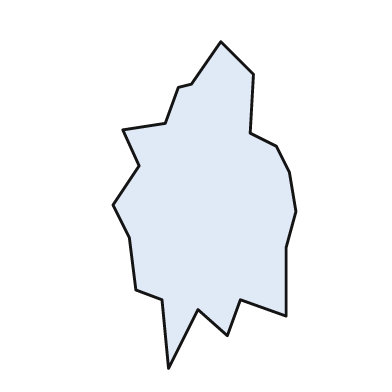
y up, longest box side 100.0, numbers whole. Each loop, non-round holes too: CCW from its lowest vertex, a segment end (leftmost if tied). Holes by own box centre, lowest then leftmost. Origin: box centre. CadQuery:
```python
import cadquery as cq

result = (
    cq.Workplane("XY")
    .moveTo(-11.0, -50.0)
    .lineTo(-2.0, -32.0)
    .lineTo(7.0, -40.0)
    .lineTo(11.0, -29.0)
    .lineTo(25.0, -34.0)
    .lineTo(25.0, -13.0)
    .lineTo(28.0, -2.0)
    .lineTo(26.0, 10.0)
    .lineTo(22.0, 18.0)
    .lineTo(14.0, 22.0)
    .lineTo(15.0, 40.0)
    .lineTo(5.0, 50.0)
    .lineTo(-4.0, 37.0)
    .lineTo(-8.0, 36.0)
    .lineTo(-12.0, 25.0)
    .lineTo(-25.0, 23.0)
    .lineTo(-20.0, 12.0)
    .lineTo(-28.0, 0.0)
    .lineTo(-23.0, -10.0)
    .lineTo(-21.0, -26.0)
    .lineTo(-13.0, -29.0)
    .close()
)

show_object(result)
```